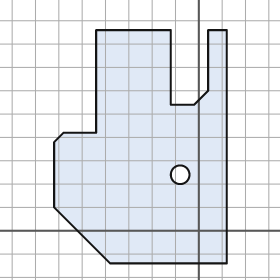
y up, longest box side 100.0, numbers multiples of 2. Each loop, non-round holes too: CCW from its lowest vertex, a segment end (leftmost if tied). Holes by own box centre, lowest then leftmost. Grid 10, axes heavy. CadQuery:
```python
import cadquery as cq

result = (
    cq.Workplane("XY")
    .moveTo(-38.0, -14.0)
    .lineTo(12.0, -14.0)
    .lineTo(12.0, 86.0)
    .lineTo(4.0, 86.0)
    .lineTo(4.0, 60.0)
    .lineTo(-2.0, 54.0)
    .lineTo(-12.0, 54.0)
    .lineTo(-12.0, 86.0)
    .lineTo(-44.0, 86.0)
    .lineTo(-44.0, 42.0)
    .lineTo(-58.0, 42.0)
    .lineTo(-62.0, 38.0)
    .lineTo(-62.0, 10.0)
    .close()
    .moveTo(-8.0, 24.0)
    .circle(4.0)
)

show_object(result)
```